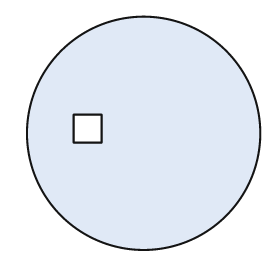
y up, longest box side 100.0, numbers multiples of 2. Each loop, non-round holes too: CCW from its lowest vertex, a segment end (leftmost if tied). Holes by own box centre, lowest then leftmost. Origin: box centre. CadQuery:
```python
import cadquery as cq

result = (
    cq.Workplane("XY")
    .moveTo(0.0, 0.0)
    .circle(50.0)
    .moveTo(-30.0, -4.0)
    .lineTo(-18.0, -4.0)
    .lineTo(-18.0, 8.0)
    .lineTo(-30.0, 8.0)
    .close()
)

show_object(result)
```